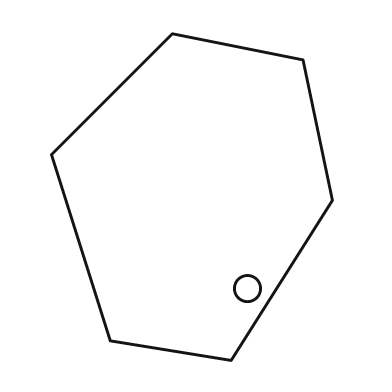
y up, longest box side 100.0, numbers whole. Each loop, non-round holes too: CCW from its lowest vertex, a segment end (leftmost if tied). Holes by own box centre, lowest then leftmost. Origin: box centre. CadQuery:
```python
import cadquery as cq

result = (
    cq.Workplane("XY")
    .moveTo(12.0, -50.0)
    .lineTo(43.0, -1.0)
    .lineTo(34.0, 42.0)
    .lineTo(-6.0, 50.0)
    .lineTo(-43.0, 13.0)
    .lineTo(-25.0, -44.0)
    .close()
    .moveTo(17.0, -28.0)
    .circle(4.0)
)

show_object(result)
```